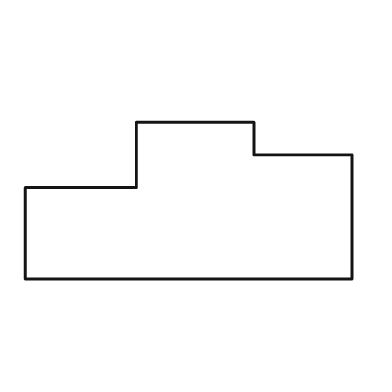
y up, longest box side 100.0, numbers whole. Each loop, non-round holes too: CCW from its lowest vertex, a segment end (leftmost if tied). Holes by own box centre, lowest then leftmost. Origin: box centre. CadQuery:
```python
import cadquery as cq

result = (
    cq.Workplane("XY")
    .moveTo(-50.0, -24.0)
    .lineTo(50.0, -24.0)
    .lineTo(50.0, 14.0)
    .lineTo(20.0, 14.0)
    .lineTo(20.0, 24.0)
    .lineTo(-16.0, 24.0)
    .lineTo(-16.0, 4.0)
    .lineTo(-50.0, 4.0)
    .close()
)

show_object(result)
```